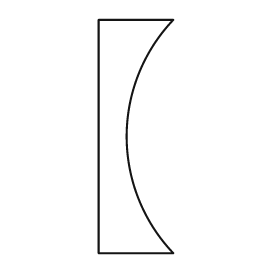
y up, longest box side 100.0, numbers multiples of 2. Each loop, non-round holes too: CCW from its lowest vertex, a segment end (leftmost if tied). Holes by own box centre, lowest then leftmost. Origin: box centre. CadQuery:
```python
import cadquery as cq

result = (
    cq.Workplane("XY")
    .moveTo(-16.0, -50.0)
    .lineTo(16.0, -50.0)
    .threePointArc((-4.0, 0.0), (16.0, 50.0))
    .lineTo(-16.0, 50.0)
    .close()
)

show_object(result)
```